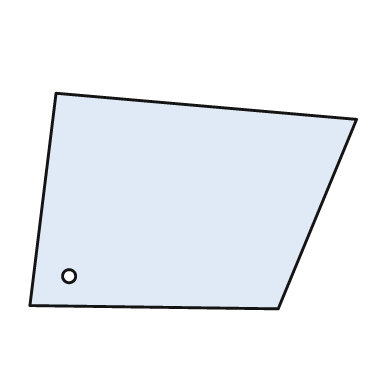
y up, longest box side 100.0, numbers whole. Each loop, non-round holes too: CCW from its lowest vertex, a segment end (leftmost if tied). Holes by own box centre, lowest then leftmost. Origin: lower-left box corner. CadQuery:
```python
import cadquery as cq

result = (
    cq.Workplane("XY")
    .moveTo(76.0, 0.0)
    .lineTo(100.0, 58.0)
    .lineTo(8.0, 66.0)
    .lineTo(0.0, 1.0)
    .close()
    .moveTo(12.0, 10.0)
    .circle(2.0)
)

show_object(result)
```